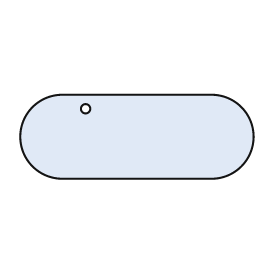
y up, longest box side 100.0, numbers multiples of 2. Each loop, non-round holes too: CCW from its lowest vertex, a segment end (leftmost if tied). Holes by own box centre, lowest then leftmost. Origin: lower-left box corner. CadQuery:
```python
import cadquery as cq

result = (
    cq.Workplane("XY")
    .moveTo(18.0, 0.0)
    .lineTo(82.0, 0.0)
    .threePointArc((100.0, 18.0), (82.0, 36.0))
    .lineTo(18.0, 36.0)
    .threePointArc((0.0, 18.0), (18.0, 0.0))
    .close()
    .moveTo(28.0, 30.0)
    .circle(2.0)
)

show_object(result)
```